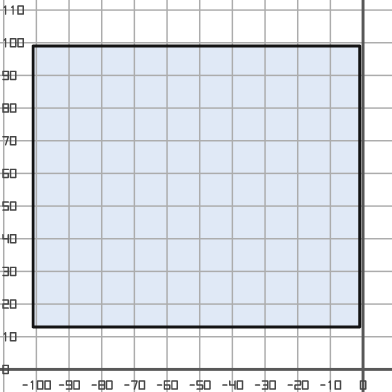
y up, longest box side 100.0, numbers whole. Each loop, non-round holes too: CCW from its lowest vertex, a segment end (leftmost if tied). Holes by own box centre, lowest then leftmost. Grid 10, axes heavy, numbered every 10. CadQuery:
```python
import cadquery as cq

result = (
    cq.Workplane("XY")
    .moveTo(-101.0, 13.0)
    .lineTo(-1.0, 13.0)
    .lineTo(-1.0, 99.0)
    .lineTo(-101.0, 99.0)
    .close()
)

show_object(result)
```